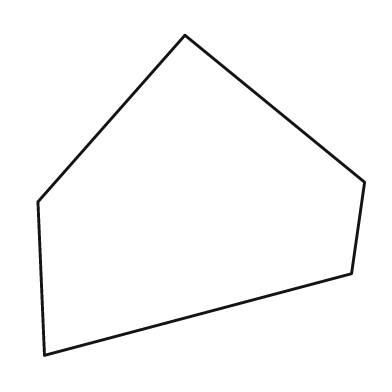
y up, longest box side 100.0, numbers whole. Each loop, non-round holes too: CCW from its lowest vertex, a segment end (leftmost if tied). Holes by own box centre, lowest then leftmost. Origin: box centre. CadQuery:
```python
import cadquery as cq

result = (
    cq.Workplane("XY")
    .moveTo(-48.0, -49.0)
    .lineTo(46.0, -24.0)
    .lineTo(50.0, 4.0)
    .lineTo(-5.0, 49.0)
    .lineTo(-50.0, -2.0)
    .close()
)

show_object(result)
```